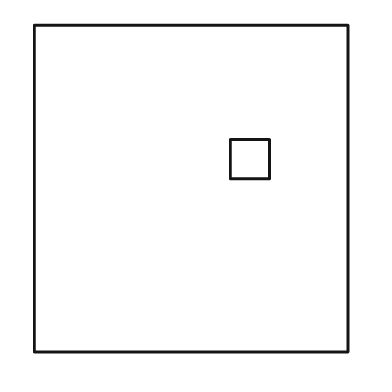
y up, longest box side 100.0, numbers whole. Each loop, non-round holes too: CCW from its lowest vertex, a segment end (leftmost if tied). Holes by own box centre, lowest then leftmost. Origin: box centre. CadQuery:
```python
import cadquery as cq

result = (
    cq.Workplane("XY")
    .moveTo(-48.0, -50.0)
    .lineTo(48.0, -50.0)
    .lineTo(48.0, 50.0)
    .lineTo(-48.0, 50.0)
    .close()
    .moveTo(12.0, 3.0)
    .lineTo(24.0, 3.0)
    .lineTo(24.0, 15.0)
    .lineTo(12.0, 15.0)
    .close()
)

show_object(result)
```